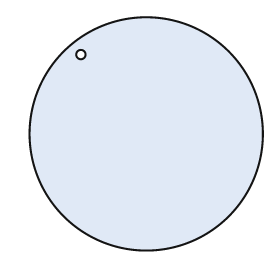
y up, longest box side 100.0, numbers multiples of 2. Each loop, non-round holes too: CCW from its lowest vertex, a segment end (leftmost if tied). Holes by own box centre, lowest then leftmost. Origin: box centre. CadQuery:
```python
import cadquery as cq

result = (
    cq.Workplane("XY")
    .moveTo(0.0, 0.0)
    .circle(50.0)
    .moveTo(-28.0, 34.0)
    .circle(2.0)
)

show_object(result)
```